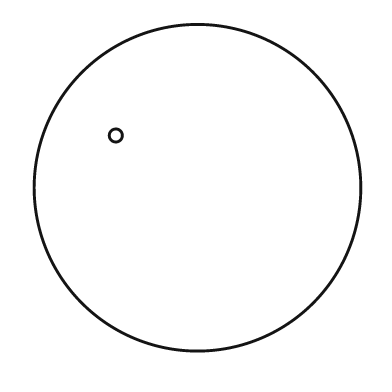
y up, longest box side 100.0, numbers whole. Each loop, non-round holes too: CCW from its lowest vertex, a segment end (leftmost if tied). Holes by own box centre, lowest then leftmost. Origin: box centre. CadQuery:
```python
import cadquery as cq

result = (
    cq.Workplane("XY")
    .moveTo(0.0, 0.0)
    .circle(50.0)
    .moveTo(-25.0, 16.0)
    .circle(2.0)
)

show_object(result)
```